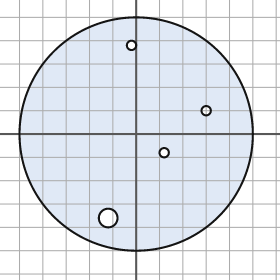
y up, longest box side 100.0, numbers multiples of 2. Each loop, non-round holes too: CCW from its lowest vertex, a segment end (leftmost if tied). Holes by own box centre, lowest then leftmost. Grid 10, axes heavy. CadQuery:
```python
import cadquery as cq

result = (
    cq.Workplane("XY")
    .moveTo(0.0, 0.0)
    .circle(50.0)
    .moveTo(-12.0, -36.0)
    .circle(4.0)
    .moveTo(12.0, -8.0)
    .circle(2.0)
    .moveTo(30.0, 10.0)
    .circle(2.0)
    .moveTo(-2.0, 38.0)
    .circle(2.0)
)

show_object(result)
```